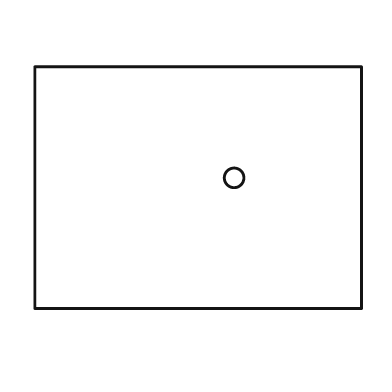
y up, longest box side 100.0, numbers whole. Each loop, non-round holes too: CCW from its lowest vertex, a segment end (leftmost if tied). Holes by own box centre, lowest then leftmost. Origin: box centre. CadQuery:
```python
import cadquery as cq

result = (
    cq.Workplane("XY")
    .moveTo(-50.0, -37.0)
    .lineTo(50.0, -37.0)
    .lineTo(50.0, 37.0)
    .lineTo(-50.0, 37.0)
    .close()
    .moveTo(11.0, 3.0)
    .circle(3.0)
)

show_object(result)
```